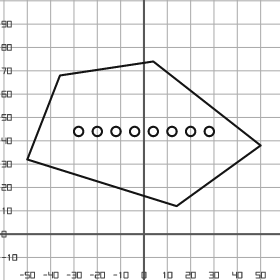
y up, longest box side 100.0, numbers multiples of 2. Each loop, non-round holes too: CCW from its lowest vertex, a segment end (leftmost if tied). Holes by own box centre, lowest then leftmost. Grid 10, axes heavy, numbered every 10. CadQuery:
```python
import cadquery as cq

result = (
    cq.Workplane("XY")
    .moveTo(14.0, 12.0)
    .lineTo(50.0, 38.0)
    .lineTo(4.0, 74.0)
    .lineTo(-36.0, 68.0)
    .lineTo(-50.0, 32.0)
    .close()
    .moveTo(-28.0, 44.0)
    .circle(2.0)
    .moveTo(-20.0, 44.0)
    .circle(2.0)
    .moveTo(-12.0, 44.0)
    .circle(2.0)
    .moveTo(-4.0, 44.0)
    .circle(2.0)
    .moveTo(4.0, 44.0)
    .circle(2.0)
    .moveTo(12.0, 44.0)
    .circle(2.0)
    .moveTo(20.0, 44.0)
    .circle(2.0)
    .moveTo(28.0, 44.0)
    .circle(2.0)
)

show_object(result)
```